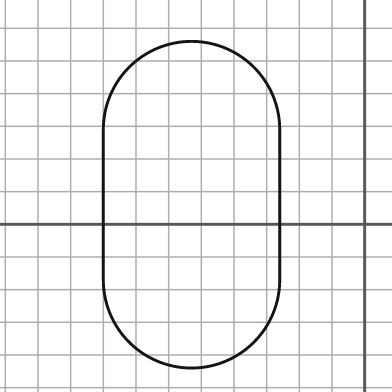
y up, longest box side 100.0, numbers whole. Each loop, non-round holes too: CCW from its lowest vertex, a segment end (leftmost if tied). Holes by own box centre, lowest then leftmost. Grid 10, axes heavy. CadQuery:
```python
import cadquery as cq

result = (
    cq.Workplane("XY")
    .moveTo(-80.0, -17.0)
    .threePointArc((-53.0, -44.0), (-26.0, -17.0))
    .lineTo(-26.0, 29.0)
    .threePointArc((-53.0, 56.0), (-80.0, 29.0))
    .close()
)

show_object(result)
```